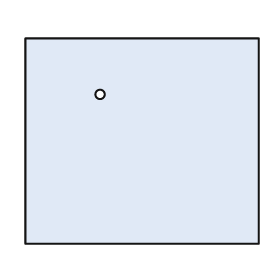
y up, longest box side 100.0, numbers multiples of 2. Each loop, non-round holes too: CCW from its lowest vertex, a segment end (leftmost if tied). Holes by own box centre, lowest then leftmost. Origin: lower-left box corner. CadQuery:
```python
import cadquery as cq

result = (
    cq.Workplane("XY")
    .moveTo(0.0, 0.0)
    .lineTo(100.0, 0.0)
    .lineTo(100.0, 88.0)
    .lineTo(0.0, 88.0)
    .close()
    .moveTo(32.0, 64.0)
    .circle(2.0)
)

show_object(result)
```